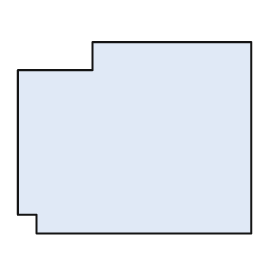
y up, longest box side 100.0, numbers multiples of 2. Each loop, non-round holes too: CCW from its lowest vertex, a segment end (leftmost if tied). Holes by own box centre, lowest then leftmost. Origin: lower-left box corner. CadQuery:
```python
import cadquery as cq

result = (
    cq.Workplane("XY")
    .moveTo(8.0, 0.0)
    .lineTo(100.0, 0.0)
    .lineTo(100.0, 82.0)
    .lineTo(32.0, 82.0)
    .lineTo(32.0, 70.0)
    .lineTo(0.0, 70.0)
    .lineTo(0.0, 8.0)
    .lineTo(8.0, 8.0)
    .close()
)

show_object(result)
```